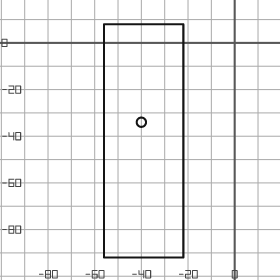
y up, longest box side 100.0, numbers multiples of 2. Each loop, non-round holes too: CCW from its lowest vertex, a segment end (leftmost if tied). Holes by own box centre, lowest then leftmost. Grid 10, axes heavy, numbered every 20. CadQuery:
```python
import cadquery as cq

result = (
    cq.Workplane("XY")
    .moveTo(-56.0, -92.0)
    .lineTo(-22.0, -92.0)
    .lineTo(-22.0, 8.0)
    .lineTo(-56.0, 8.0)
    .close()
    .moveTo(-40.0, -34.0)
    .circle(2.0)
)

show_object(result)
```